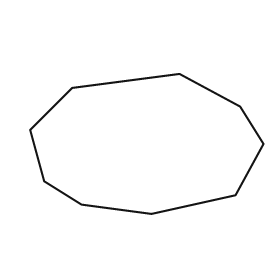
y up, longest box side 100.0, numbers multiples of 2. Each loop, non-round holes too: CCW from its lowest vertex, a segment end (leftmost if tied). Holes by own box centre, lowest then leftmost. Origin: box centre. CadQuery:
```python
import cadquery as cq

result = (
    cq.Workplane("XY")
    .moveTo(2.0, -30.0)
    .lineTo(38.0, -22.0)
    .lineTo(50.0, 0.0)
    .lineTo(40.0, 16.0)
    .lineTo(14.0, 30.0)
    .lineTo(-32.0, 24.0)
    .lineTo(-50.0, 6.0)
    .lineTo(-44.0, -16.0)
    .lineTo(-28.0, -26.0)
    .close()
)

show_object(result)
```